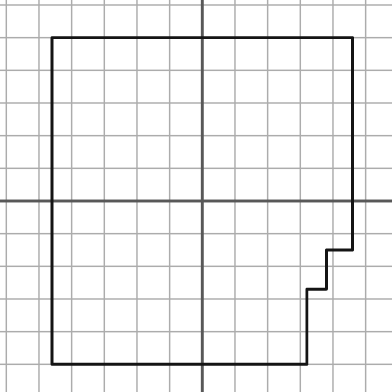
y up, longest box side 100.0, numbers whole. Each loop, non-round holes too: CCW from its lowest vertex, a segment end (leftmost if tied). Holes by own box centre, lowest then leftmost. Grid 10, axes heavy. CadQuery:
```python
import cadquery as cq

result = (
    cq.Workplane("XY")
    .moveTo(-46.0, -50.0)
    .lineTo(32.0, -50.0)
    .lineTo(32.0, -27.0)
    .lineTo(38.0, -27.0)
    .lineTo(38.0, -15.0)
    .lineTo(46.0, -15.0)
    .lineTo(46.0, 50.0)
    .lineTo(-46.0, 50.0)
    .close()
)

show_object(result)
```